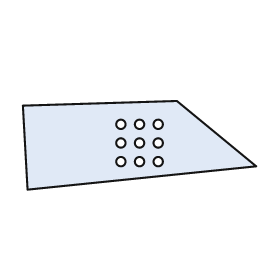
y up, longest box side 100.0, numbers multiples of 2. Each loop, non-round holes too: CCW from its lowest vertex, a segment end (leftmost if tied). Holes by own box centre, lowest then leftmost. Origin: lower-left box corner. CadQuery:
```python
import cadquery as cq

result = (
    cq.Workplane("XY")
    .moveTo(2.0, 0.0)
    .lineTo(100.0, 10.0)
    .lineTo(66.0, 38.0)
    .lineTo(0.0, 36.0)
    .close()
    .moveTo(42.0, 12.0)
    .circle(2.0)
    .moveTo(50.0, 12.0)
    .circle(2.0)
    .moveTo(58.0, 12.0)
    .circle(2.0)
    .moveTo(42.0, 20.0)
    .circle(2.0)
    .moveTo(50.0, 20.0)
    .circle(2.0)
    .moveTo(58.0, 20.0)
    .circle(2.0)
    .moveTo(42.0, 28.0)
    .circle(2.0)
    .moveTo(50.0, 28.0)
    .circle(2.0)
    .moveTo(58.0, 28.0)
    .circle(2.0)
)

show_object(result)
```